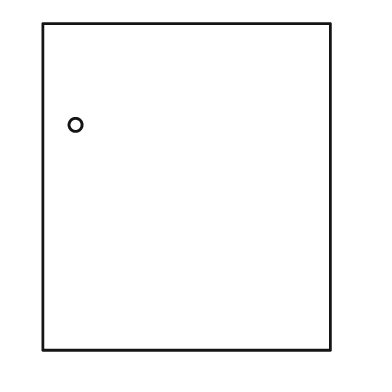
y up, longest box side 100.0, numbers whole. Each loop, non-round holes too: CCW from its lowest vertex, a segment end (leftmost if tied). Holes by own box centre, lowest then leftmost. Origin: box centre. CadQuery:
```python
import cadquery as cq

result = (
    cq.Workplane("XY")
    .moveTo(-44.0, -50.0)
    .lineTo(44.0, -50.0)
    .lineTo(44.0, 50.0)
    .lineTo(-44.0, 50.0)
    .close()
    .moveTo(-34.0, 19.0)
    .circle(2.0)
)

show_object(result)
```